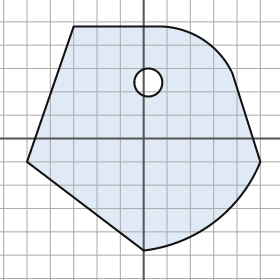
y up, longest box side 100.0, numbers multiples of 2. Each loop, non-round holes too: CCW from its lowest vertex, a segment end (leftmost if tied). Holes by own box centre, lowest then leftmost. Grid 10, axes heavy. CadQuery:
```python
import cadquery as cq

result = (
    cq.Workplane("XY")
    .moveTo(0.0, -48.0)
    .threePointArc((30.0, -36.0), (50.0, -10.0))
    .lineTo(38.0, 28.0)
    .threePointArc((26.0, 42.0), (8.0, 48.0))
    .lineTo(-30.0, 48.0)
    .lineTo(-50.0, -10.0)
    .close()
    .moveTo(2.0, 24.0)
    .circle(6.0)
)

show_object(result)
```